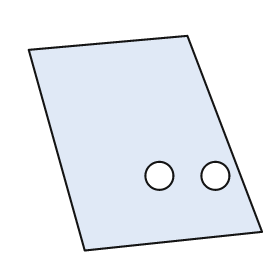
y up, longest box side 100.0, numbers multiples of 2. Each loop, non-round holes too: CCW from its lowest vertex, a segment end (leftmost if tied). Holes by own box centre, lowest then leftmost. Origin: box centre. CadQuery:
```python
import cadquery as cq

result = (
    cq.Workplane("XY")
    .moveTo(-26.0, -46.0)
    .lineTo(50.0, -38.0)
    .lineTo(18.0, 46.0)
    .lineTo(-50.0, 40.0)
    .close()
    .moveTo(6.0, -14.0)
    .circle(6.0)
    .moveTo(30.0, -14.0)
    .circle(6.0)
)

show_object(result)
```